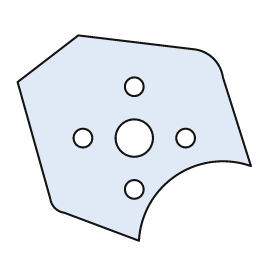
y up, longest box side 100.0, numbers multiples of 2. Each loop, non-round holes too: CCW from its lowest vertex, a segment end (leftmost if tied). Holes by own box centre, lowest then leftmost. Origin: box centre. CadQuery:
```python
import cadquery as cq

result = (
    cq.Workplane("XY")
    .moveTo(2.0, -44.0)
    .threePointArc((18.0, -16.0), (50.0, -12.0))
    .lineTo(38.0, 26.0)
    .threePointArc((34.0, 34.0), (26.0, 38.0))
    .lineTo(-24.0, 44.0)
    .lineTo(-50.0, 24.0)
    .lineTo(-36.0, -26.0)
    .threePointArc((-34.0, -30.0), (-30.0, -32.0))
    .close()
    .moveTo(0.0, -22.0)
    .circle(4.0)
    .moveTo(-22.0, 0.0)
    .circle(4.0)
    .moveTo(0.0, 0.0)
    .circle(8.0)
    .moveTo(22.0, 0.0)
    .circle(4.0)
    .moveTo(0.0, 22.0)
    .circle(4.0)
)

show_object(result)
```